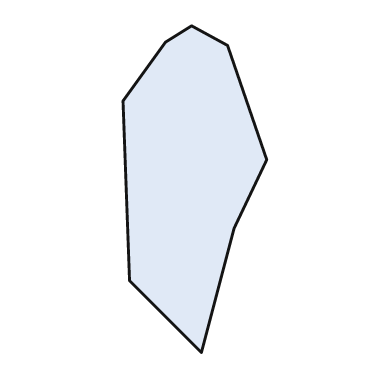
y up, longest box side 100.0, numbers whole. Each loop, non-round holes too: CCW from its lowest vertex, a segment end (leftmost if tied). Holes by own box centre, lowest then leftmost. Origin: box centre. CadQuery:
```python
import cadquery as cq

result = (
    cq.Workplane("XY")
    .moveTo(2.0, -50.0)
    .lineTo(12.0, -12.0)
    .lineTo(22.0, 9.0)
    .lineTo(10.0, 44.0)
    .lineTo(-1.0, 50.0)
    .lineTo(-9.0, 45.0)
    .lineTo(-22.0, 27.0)
    .lineTo(-20.0, -28.0)
    .close()
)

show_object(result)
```